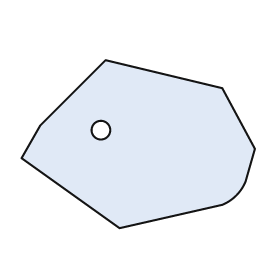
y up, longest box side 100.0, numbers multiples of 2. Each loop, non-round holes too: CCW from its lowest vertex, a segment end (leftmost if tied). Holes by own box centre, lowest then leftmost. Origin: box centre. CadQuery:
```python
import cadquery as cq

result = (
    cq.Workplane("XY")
    .moveTo(-8.0, -36.0)
    .lineTo(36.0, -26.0)
    .threePointArc((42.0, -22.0), (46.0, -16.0))
    .lineTo(50.0, -2.0)
    .lineTo(36.0, 24.0)
    .lineTo(-14.0, 36.0)
    .lineTo(-42.0, 8.0)
    .lineTo(-50.0, -6.0)
    .close()
    .moveTo(-16.0, 6.0)
    .circle(4.0)
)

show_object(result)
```